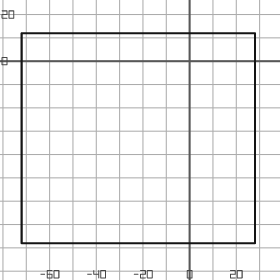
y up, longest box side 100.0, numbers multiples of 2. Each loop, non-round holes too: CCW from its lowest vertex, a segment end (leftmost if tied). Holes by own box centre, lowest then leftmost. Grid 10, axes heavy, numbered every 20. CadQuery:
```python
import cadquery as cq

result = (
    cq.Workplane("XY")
    .moveTo(-72.0, -78.0)
    .lineTo(28.0, -78.0)
    .lineTo(28.0, 12.0)
    .lineTo(-72.0, 12.0)
    .close()
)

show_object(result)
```